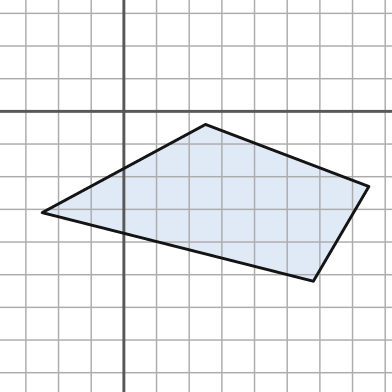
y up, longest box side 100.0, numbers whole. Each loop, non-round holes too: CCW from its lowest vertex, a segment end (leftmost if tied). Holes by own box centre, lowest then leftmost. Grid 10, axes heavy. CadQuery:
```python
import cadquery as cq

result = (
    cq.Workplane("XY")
    .moveTo(58.0, -52.0)
    .lineTo(75.0, -23.0)
    .lineTo(25.0, -4.0)
    .lineTo(-25.0, -31.0)
    .close()
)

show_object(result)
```